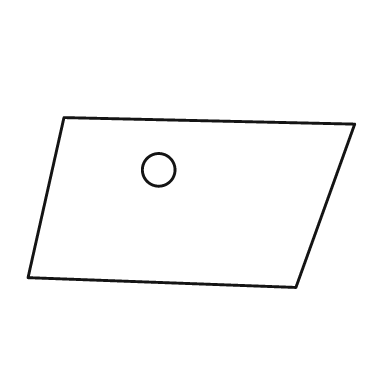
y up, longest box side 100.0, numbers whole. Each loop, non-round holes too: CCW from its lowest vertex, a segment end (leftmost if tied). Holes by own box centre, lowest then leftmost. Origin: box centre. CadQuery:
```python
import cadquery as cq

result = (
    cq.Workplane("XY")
    .moveTo(32.0, -26.0)
    .lineTo(50.0, 24.0)
    .lineTo(-39.0, 26.0)
    .lineTo(-50.0, -23.0)
    .close()
    .moveTo(-10.0, 10.0)
    .circle(5.0)
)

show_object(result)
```